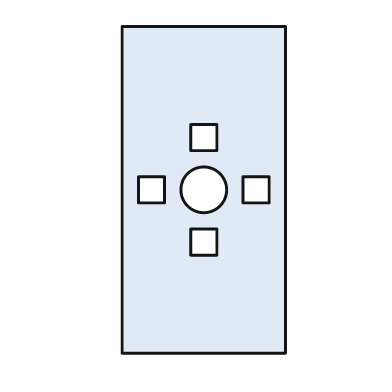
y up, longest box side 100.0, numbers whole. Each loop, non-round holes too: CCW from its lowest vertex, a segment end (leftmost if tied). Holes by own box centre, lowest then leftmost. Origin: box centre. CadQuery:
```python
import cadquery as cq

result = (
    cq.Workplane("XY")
    .moveTo(-25.0, -50.0)
    .lineTo(25.0, -50.0)
    .lineTo(25.0, 50.0)
    .lineTo(-25.0, 50.0)
    .close()
    .moveTo(-4.0, -20.0)
    .lineTo(4.0, -20.0)
    .lineTo(4.0, -12.0)
    .lineTo(-4.0, -12.0)
    .close()
    .moveTo(-20.0, -4.0)
    .lineTo(-12.0, -4.0)
    .lineTo(-12.0, 4.0)
    .lineTo(-20.0, 4.0)
    .close()
    .moveTo(0.0, 0.0)
    .circle(7.0)
    .moveTo(12.0, -4.0)
    .lineTo(20.0, -4.0)
    .lineTo(20.0, 4.0)
    .lineTo(12.0, 4.0)
    .close()
    .moveTo(-4.0, 12.0)
    .lineTo(4.0, 12.0)
    .lineTo(4.0, 20.0)
    .lineTo(-4.0, 20.0)
    .close()
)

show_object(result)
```